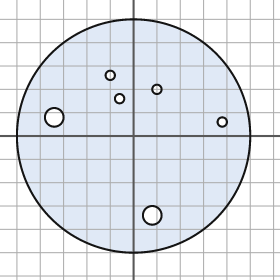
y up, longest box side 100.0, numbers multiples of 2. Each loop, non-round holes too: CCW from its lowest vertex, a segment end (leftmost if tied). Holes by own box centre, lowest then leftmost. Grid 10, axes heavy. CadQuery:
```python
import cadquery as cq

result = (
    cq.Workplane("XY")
    .moveTo(0.0, 0.0)
    .circle(50.0)
    .moveTo(8.0, -34.0)
    .circle(4.0)
    .moveTo(38.0, 6.0)
    .circle(2.0)
    .moveTo(-34.0, 8.0)
    .circle(4.0)
    .moveTo(-6.0, 16.0)
    .circle(2.0)
    .moveTo(10.0, 20.0)
    .circle(2.0)
    .moveTo(-10.0, 26.0)
    .circle(2.0)
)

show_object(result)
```